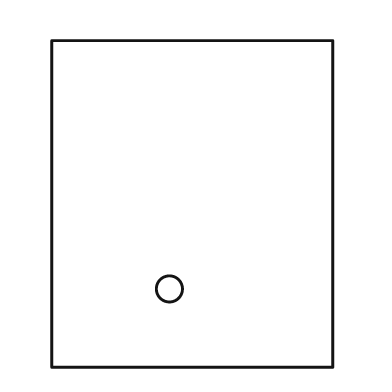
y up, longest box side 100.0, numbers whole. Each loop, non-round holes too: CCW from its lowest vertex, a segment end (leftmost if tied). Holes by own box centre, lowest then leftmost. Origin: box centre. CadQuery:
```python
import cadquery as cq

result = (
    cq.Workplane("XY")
    .moveTo(-43.0, -50.0)
    .lineTo(43.0, -50.0)
    .lineTo(43.0, 50.0)
    .lineTo(-43.0, 50.0)
    .close()
    .moveTo(-7.0, -26.0)
    .circle(4.0)
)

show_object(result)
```